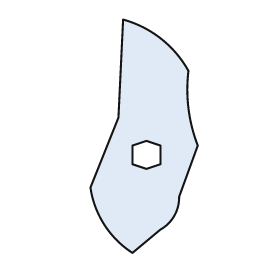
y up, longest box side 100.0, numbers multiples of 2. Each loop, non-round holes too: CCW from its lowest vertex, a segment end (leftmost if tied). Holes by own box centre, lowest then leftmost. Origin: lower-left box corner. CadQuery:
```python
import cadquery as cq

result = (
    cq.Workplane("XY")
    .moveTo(18.0, 0.0)
    .lineTo(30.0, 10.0)
    .threePointArc((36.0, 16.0), (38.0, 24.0))
    .lineTo(46.0, 46.0)
    .threePointArc((42.0, 62.0), (42.0, 78.0))
    .threePointArc((30.0, 92.0), (14.0, 100.0))
    .lineTo(12.0, 58.0)
    .lineTo(0.0, 28.0)
    .threePointArc((6.0, 12.0), (18.0, 0.0))
    .close()
    .moveTo(24.0, 36.0)
    .lineTo(30.0, 38.0)
    .lineTo(30.0, 46.0)
    .lineTo(24.0, 48.0)
    .lineTo(18.0, 46.0)
    .lineTo(18.0, 38.0)
    .close()
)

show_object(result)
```